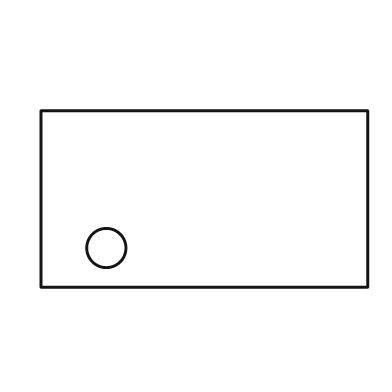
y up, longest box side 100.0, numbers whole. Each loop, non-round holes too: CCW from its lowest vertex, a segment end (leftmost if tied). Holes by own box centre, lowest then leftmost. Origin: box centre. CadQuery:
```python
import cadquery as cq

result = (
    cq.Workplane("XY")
    .moveTo(-50.0, -27.0)
    .lineTo(50.0, -27.0)
    .lineTo(50.0, 27.0)
    .lineTo(-50.0, 27.0)
    .close()
    .moveTo(-30.0, -15.0)
    .circle(6.0)
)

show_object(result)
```